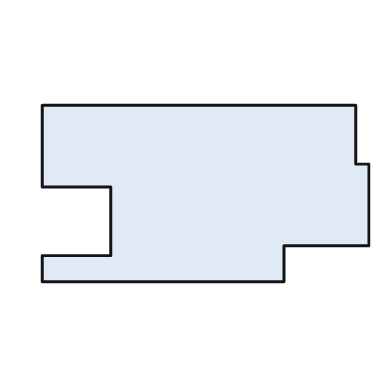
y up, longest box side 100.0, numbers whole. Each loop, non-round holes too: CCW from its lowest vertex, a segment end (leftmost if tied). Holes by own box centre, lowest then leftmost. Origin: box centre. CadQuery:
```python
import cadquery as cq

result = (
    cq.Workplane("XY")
    .moveTo(-50.0, -27.0)
    .lineTo(24.0, -27.0)
    .lineTo(24.0, -16.0)
    .lineTo(50.0, -16.0)
    .lineTo(50.0, 9.0)
    .lineTo(46.0, 9.0)
    .lineTo(46.0, 27.0)
    .lineTo(-50.0, 27.0)
    .lineTo(-50.0, 2.0)
    .lineTo(-29.0, 2.0)
    .lineTo(-29.0, -19.0)
    .lineTo(-50.0, -19.0)
    .close()
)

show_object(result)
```